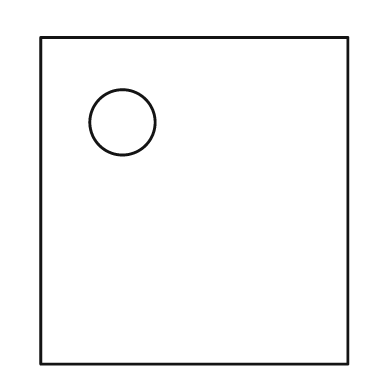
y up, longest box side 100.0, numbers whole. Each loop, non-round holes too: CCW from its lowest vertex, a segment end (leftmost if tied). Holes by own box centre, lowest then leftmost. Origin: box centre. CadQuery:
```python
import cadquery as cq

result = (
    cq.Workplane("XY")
    .moveTo(-47.0, -50.0)
    .lineTo(47.0, -50.0)
    .lineTo(47.0, 50.0)
    .lineTo(-47.0, 50.0)
    .close()
    .moveTo(-22.0, 24.0)
    .circle(10.0)
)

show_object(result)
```